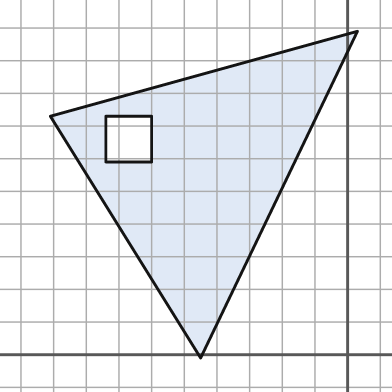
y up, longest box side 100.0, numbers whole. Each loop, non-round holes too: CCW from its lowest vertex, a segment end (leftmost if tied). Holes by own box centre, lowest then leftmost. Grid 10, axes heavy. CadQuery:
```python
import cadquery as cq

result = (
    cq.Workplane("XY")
    .moveTo(-45.0, -1.0)
    .lineTo(3.0, 99.0)
    .lineTo(-91.0, 73.0)
    .close()
    .moveTo(-74.0, 59.0)
    .lineTo(-60.0, 59.0)
    .lineTo(-60.0, 73.0)
    .lineTo(-74.0, 73.0)
    .close()
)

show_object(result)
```